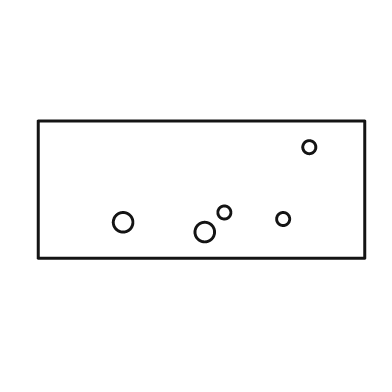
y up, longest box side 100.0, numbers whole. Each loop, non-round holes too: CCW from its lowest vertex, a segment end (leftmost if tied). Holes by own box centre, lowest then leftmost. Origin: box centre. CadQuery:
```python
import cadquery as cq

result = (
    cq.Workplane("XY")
    .moveTo(-50.0, -21.0)
    .lineTo(50.0, -21.0)
    .lineTo(50.0, 21.0)
    .lineTo(-50.0, 21.0)
    .close()
    .moveTo(1.0, -13.0)
    .circle(3.0)
    .moveTo(-24.0, -10.0)
    .circle(3.0)
    .moveTo(25.0, -9.0)
    .circle(2.0)
    .moveTo(7.0, -7.0)
    .circle(2.0)
    .moveTo(33.0, 13.0)
    .circle(2.0)
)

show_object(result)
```